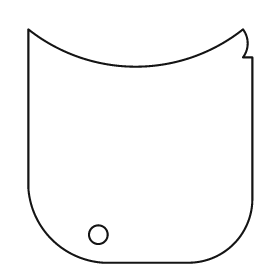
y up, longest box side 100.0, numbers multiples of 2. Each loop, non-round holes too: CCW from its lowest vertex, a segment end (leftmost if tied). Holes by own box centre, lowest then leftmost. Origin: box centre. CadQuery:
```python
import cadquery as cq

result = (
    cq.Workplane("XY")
    .moveTo(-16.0, -50.0)
    .lineTo(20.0, -50.0)
    .threePointArc((40.0, -42.0), (48.0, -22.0))
    .lineTo(48.0, 38.0)
    .lineTo(44.0, 38.0)
    .threePointArc((46.0, 44.0), (44.0, 50.0))
    .threePointArc((-2.0, 34.0), (-48.0, 50.0))
    .lineTo(-48.0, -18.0)
    .threePointArc((-38.0, -40.0), (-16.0, -50.0))
    .close()
    .moveTo(-18.0, -38.0)
    .circle(4.0)
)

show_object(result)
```